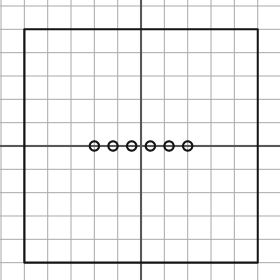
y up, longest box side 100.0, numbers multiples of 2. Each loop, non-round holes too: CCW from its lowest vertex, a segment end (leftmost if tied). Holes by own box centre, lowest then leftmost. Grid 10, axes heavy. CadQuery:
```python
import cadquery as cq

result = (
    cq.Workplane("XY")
    .moveTo(-50.0, -50.0)
    .lineTo(50.0, -50.0)
    .lineTo(50.0, 50.0)
    .lineTo(-50.0, 50.0)
    .close()
    .moveTo(-20.0, 0.0)
    .circle(2.0)
    .moveTo(-12.0, 0.0)
    .circle(2.0)
    .moveTo(-4.0, 0.0)
    .circle(2.0)
    .moveTo(4.0, 0.0)
    .circle(2.0)
    .moveTo(12.0, 0.0)
    .circle(2.0)
    .moveTo(20.0, 0.0)
    .circle(2.0)
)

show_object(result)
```